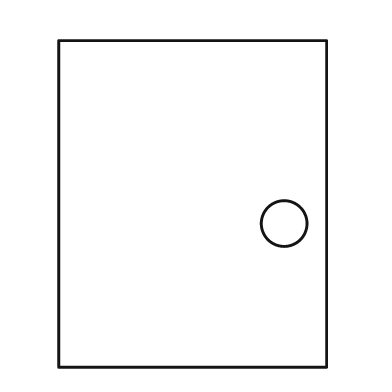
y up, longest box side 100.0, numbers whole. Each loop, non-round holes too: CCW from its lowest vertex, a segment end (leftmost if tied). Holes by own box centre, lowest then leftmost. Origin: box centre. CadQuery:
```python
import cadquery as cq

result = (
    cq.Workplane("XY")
    .moveTo(-41.0, -50.0)
    .lineTo(41.0, -50.0)
    .lineTo(41.0, 50.0)
    .lineTo(-41.0, 50.0)
    .close()
    .moveTo(28.0, -6.0)
    .circle(7.0)
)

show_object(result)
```